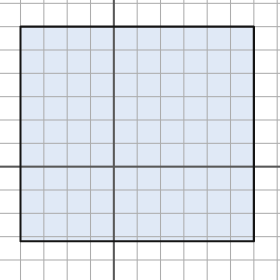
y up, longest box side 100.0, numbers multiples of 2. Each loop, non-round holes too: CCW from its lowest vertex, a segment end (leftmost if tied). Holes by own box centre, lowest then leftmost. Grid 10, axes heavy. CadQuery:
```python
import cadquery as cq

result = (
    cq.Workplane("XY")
    .moveTo(-40.0, -32.0)
    .lineTo(60.0, -32.0)
    .lineTo(60.0, 60.0)
    .lineTo(-40.0, 60.0)
    .close()
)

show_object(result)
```